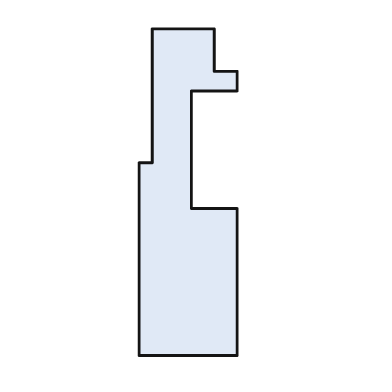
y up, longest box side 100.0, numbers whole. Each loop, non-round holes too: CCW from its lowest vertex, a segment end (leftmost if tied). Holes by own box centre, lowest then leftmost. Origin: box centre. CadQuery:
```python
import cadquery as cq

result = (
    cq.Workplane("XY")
    .moveTo(-15.0, -50.0)
    .lineTo(15.0, -50.0)
    .lineTo(15.0, -5.0)
    .lineTo(1.0, -5.0)
    .lineTo(1.0, 31.0)
    .lineTo(15.0, 31.0)
    .lineTo(15.0, 37.0)
    .lineTo(8.0, 37.0)
    .lineTo(8.0, 50.0)
    .lineTo(-11.0, 50.0)
    .lineTo(-11.0, 9.0)
    .lineTo(-15.0, 9.0)
    .close()
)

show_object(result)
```